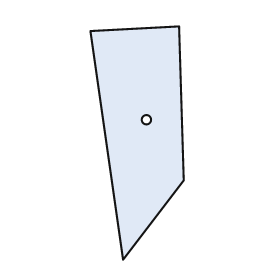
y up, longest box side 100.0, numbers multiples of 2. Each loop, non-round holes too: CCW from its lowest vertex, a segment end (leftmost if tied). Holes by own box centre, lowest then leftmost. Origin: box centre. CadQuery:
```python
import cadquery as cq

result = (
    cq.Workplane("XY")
    .moveTo(-6.0, -50.0)
    .lineTo(20.0, -16.0)
    .lineTo(18.0, 50.0)
    .lineTo(-20.0, 48.0)
    .close()
    .moveTo(4.0, 10.0)
    .circle(2.0)
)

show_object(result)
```